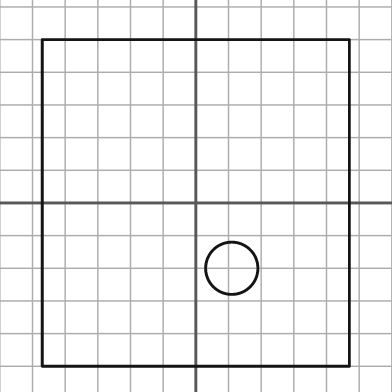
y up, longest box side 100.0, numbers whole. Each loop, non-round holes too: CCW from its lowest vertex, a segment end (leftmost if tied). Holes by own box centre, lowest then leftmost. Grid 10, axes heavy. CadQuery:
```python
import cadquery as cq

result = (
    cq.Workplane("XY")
    .moveTo(-47.0, -50.0)
    .lineTo(47.0, -50.0)
    .lineTo(47.0, 50.0)
    .lineTo(-47.0, 50.0)
    .close()
    .moveTo(11.0, -20.0)
    .circle(8.0)
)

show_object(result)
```